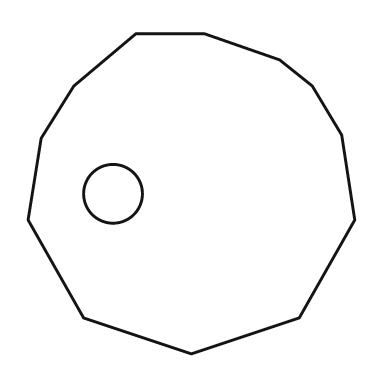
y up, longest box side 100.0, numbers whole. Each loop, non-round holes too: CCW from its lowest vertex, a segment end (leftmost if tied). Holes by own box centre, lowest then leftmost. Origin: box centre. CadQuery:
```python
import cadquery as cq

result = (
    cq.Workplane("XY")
    .moveTo(0.0, -49.0)
    .lineTo(33.0, -38.0)
    .lineTo(50.0, -8.0)
    .lineTo(46.0, 18.0)
    .lineTo(37.0, 33.0)
    .lineTo(27.0, 41.0)
    .lineTo(4.0, 49.0)
    .lineTo(-17.0, 49.0)
    .lineTo(-36.0, 33.0)
    .lineTo(-46.0, 17.0)
    .lineTo(-50.0, -8.0)
    .lineTo(-33.0, -38.0)
    .close()
    .moveTo(-24.0, 0.0)
    .circle(9.0)
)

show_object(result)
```